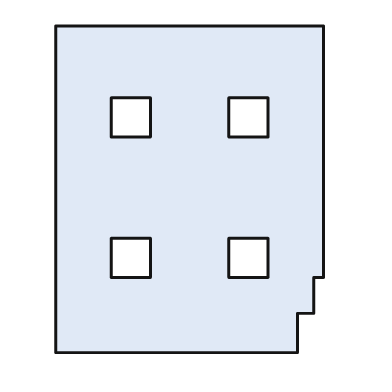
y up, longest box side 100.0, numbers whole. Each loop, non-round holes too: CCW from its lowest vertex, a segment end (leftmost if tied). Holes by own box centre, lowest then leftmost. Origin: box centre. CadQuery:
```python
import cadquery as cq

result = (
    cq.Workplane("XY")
    .moveTo(-41.0, -50.0)
    .lineTo(33.0, -50.0)
    .lineTo(33.0, -38.0)
    .lineTo(38.0, -38.0)
    .lineTo(38.0, -27.0)
    .lineTo(41.0, -27.0)
    .lineTo(41.0, 50.0)
    .lineTo(-41.0, 50.0)
    .close()
    .moveTo(-24.0, -27.0)
    .lineTo(-12.0, -27.0)
    .lineTo(-12.0, -15.0)
    .lineTo(-24.0, -15.0)
    .close()
    .moveTo(12.0, -27.0)
    .lineTo(24.0, -27.0)
    .lineTo(24.0, -15.0)
    .lineTo(12.0, -15.0)
    .close()
    .moveTo(-24.0, 16.0)
    .lineTo(-12.0, 16.0)
    .lineTo(-12.0, 28.0)
    .lineTo(-24.0, 28.0)
    .close()
    .moveTo(12.0, 16.0)
    .lineTo(24.0, 16.0)
    .lineTo(24.0, 28.0)
    .lineTo(12.0, 28.0)
    .close()
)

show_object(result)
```